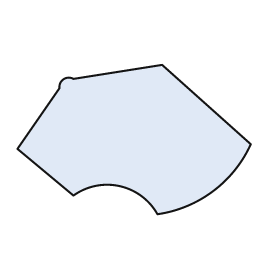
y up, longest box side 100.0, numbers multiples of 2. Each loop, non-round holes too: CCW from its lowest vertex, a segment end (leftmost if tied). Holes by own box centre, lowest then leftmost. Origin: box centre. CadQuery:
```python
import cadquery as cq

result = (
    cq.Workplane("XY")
    .moveTo(10.0, -32.0)
    .threePointArc((34.0, -22.0), (50.0, -2.0))
    .lineTo(12.0, 32.0)
    .lineTo(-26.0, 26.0)
    .threePointArc((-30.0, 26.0), (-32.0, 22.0))
    .lineTo(-50.0, -4.0)
    .lineTo(-26.0, -24.0)
    .threePointArc((-6.0, -20.0), (10.0, -32.0))
    .close()
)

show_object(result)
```